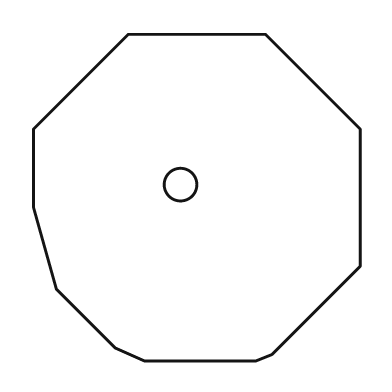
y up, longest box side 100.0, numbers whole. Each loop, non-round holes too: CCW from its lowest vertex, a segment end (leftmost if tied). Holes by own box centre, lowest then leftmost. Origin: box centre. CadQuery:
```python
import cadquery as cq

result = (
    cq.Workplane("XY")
    .moveTo(-16.0, -50.0)
    .lineTo(18.0, -50.0)
    .lineTo(23.0, -48.0)
    .lineTo(50.0, -21.0)
    .lineTo(50.0, 21.0)
    .lineTo(21.0, 50.0)
    .lineTo(-21.0, 50.0)
    .lineTo(-50.0, 21.0)
    .lineTo(-50.0, -3.0)
    .lineTo(-43.0, -28.0)
    .lineTo(-25.0, -46.0)
    .close()
    .moveTo(-5.0, 4.0)
    .circle(5.0)
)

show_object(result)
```